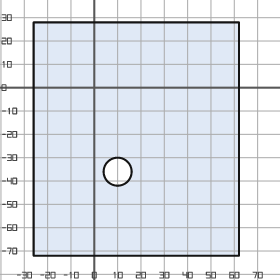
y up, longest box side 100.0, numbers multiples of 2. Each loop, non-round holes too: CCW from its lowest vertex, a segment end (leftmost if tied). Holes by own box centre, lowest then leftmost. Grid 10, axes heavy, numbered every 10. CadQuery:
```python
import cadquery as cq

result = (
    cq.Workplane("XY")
    .moveTo(-26.0, -72.0)
    .lineTo(62.0, -72.0)
    .lineTo(62.0, 28.0)
    .lineTo(-26.0, 28.0)
    .close()
    .moveTo(10.0, -36.0)
    .circle(6.0)
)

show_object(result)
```